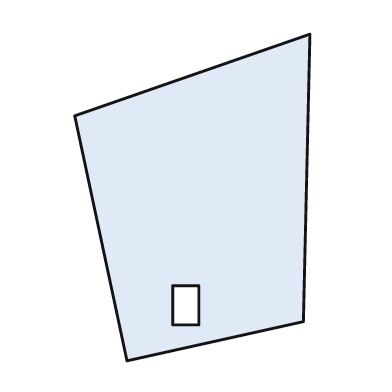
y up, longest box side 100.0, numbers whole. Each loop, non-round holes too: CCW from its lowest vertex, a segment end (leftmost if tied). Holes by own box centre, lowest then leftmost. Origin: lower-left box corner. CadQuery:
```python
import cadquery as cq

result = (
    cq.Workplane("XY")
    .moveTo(16.0, 0.0)
    .lineTo(70.0, 12.0)
    .lineTo(72.0, 100.0)
    .lineTo(0.0, 75.0)
    .close()
    .moveTo(30.0, 11.0)
    .lineTo(38.0, 11.0)
    .lineTo(38.0, 23.0)
    .lineTo(30.0, 23.0)
    .close()
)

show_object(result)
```